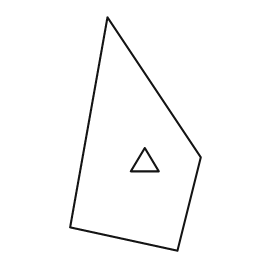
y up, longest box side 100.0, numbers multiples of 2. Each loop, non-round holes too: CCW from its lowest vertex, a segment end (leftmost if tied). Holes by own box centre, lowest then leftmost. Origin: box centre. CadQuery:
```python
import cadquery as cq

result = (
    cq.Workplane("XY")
    .moveTo(18.0, -50.0)
    .lineTo(28.0, -10.0)
    .lineTo(-12.0, 50.0)
    .lineTo(-28.0, -40.0)
    .close()
    .moveTo(-2.0, -16.0)
    .lineTo(10.0, -16.0)
    .lineTo(4.0, -6.0)
    .close()
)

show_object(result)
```